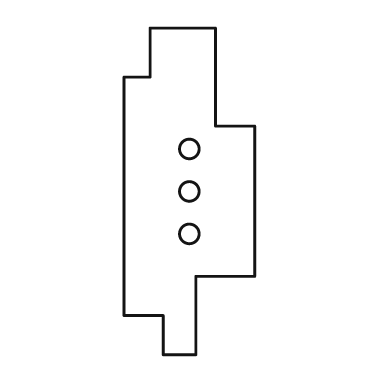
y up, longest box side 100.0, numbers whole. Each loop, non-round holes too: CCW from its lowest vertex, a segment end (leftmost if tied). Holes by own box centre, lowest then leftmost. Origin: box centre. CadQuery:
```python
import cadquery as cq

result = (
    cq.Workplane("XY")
    .moveTo(-8.0, -50.0)
    .lineTo(2.0, -50.0)
    .lineTo(2.0, -26.0)
    .lineTo(20.0, -26.0)
    .lineTo(20.0, 20.0)
    .lineTo(8.0, 20.0)
    .lineTo(8.0, 50.0)
    .lineTo(-12.0, 50.0)
    .lineTo(-12.0, 35.0)
    .lineTo(-20.0, 35.0)
    .lineTo(-20.0, -38.0)
    .lineTo(-8.0, -38.0)
    .close()
    .moveTo(0.0, -13.0)
    .circle(3.0)
    .moveTo(0.0, 0.0)
    .circle(3.0)
    .moveTo(0.0, 13.0)
    .circle(3.0)
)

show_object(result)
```